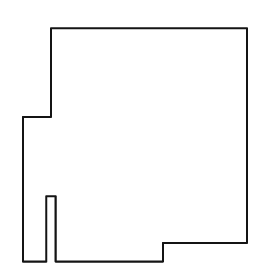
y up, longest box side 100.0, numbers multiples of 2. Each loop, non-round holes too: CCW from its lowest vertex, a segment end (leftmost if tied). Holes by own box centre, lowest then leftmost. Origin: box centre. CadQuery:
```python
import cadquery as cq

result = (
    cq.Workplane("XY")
    .moveTo(-48.0, -50.0)
    .lineTo(-38.0, -50.0)
    .lineTo(-38.0, -22.0)
    .lineTo(-34.0, -22.0)
    .lineTo(-34.0, -50.0)
    .lineTo(12.0, -50.0)
    .lineTo(12.0, -42.0)
    .lineTo(48.0, -42.0)
    .lineTo(48.0, 50.0)
    .lineTo(-36.0, 50.0)
    .lineTo(-36.0, 12.0)
    .lineTo(-48.0, 12.0)
    .close()
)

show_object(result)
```